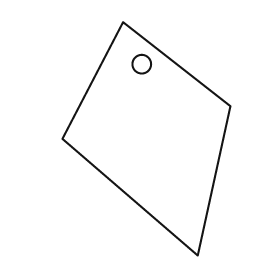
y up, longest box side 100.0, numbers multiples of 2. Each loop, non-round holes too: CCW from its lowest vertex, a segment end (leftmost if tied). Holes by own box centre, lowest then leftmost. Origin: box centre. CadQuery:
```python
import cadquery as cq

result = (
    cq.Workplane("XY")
    .moveTo(22.0, -50.0)
    .lineTo(36.0, 14.0)
    .lineTo(-10.0, 50.0)
    .lineTo(-36.0, 0.0)
    .close()
    .moveTo(-2.0, 32.0)
    .circle(4.0)
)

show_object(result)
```